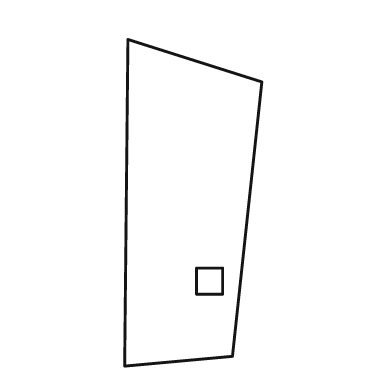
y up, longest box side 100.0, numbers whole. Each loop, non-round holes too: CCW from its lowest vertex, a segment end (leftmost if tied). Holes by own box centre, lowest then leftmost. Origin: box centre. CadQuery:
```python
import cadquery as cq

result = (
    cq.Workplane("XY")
    .moveTo(-21.0, -50.0)
    .lineTo(12.0, -47.0)
    .lineTo(21.0, 37.0)
    .lineTo(-20.0, 50.0)
    .close()
    .moveTo(1.0, -28.0)
    .lineTo(9.0, -28.0)
    .lineTo(9.0, -20.0)
    .lineTo(1.0, -20.0)
    .close()
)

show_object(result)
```